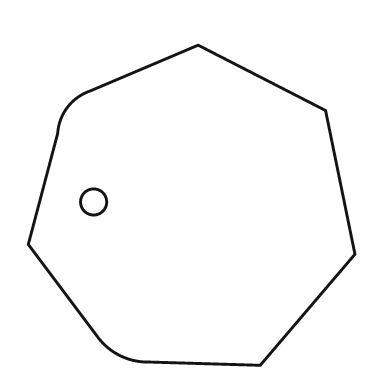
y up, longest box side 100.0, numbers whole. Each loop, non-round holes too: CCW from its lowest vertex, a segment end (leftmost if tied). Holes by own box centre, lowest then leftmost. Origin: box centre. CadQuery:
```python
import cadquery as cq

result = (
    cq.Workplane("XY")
    .moveTo(21.0, -49.0)
    .lineTo(50.0, -15.0)
    .lineTo(41.0, 29.0)
    .lineTo(2.0, 49.0)
    .lineTo(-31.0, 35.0)
    .threePointArc((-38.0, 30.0), (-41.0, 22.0))
    .lineTo(-50.0, -12.0)
    .lineTo(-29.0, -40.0)
    .threePointArc((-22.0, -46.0), (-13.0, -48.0))
    .close()
    .moveTo(-30.0, 1.0)
    .circle(4.0)
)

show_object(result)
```